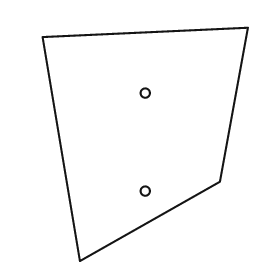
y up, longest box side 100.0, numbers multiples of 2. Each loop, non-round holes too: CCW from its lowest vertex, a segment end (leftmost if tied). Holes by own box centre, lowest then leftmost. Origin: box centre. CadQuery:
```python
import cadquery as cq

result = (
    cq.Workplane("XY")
    .moveTo(-28.0, -50.0)
    .lineTo(32.0, -16.0)
    .lineTo(44.0, 50.0)
    .lineTo(-44.0, 46.0)
    .close()
    .moveTo(0.0, -20.0)
    .circle(2.0)
    .moveTo(0.0, 22.0)
    .circle(2.0)
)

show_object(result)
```